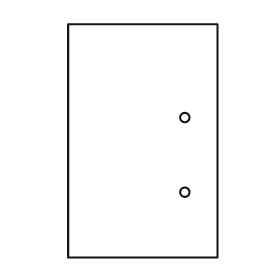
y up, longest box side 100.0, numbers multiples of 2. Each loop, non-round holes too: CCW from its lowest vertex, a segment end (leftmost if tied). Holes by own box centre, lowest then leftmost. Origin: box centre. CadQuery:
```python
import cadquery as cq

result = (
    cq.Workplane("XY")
    .moveTo(-32.0, -50.0)
    .lineTo(32.0, -50.0)
    .lineTo(32.0, 50.0)
    .lineTo(-32.0, 50.0)
    .close()
    .moveTo(18.0, -22.0)
    .circle(2.0)
    .moveTo(18.0, 10.0)
    .circle(2.0)
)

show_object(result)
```